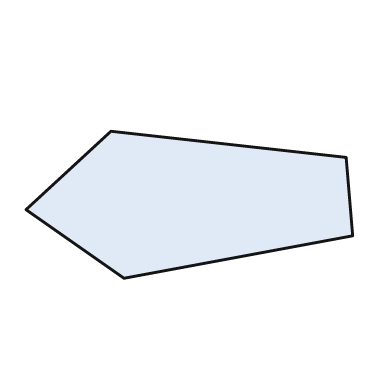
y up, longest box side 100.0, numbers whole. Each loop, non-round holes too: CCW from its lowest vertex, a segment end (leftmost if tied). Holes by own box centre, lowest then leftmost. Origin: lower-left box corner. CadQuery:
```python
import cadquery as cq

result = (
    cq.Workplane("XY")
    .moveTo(30.0, 0.0)
    .lineTo(100.0, 13.0)
    .lineTo(98.0, 37.0)
    .lineTo(26.0, 45.0)
    .lineTo(0.0, 21.0)
    .close()
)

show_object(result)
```